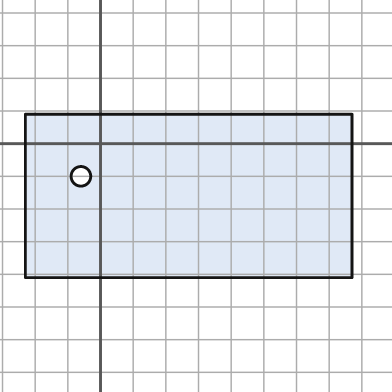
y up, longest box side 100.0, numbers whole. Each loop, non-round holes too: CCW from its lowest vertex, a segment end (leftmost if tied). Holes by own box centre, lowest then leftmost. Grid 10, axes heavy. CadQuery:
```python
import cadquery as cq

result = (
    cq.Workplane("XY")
    .moveTo(-23.0, -41.0)
    .lineTo(77.0, -41.0)
    .lineTo(77.0, 9.0)
    .lineTo(-23.0, 9.0)
    .close()
    .moveTo(-6.0, -10.0)
    .circle(3.0)
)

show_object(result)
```